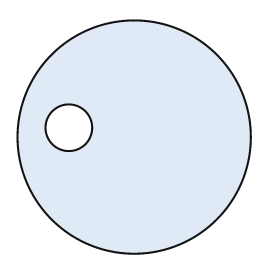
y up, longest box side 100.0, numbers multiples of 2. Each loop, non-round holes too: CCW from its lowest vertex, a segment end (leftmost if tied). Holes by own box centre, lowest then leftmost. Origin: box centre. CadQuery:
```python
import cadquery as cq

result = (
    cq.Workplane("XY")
    .moveTo(0.0, 0.0)
    .circle(50.0)
    .moveTo(-28.0, 4.0)
    .circle(10.0)
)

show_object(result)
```